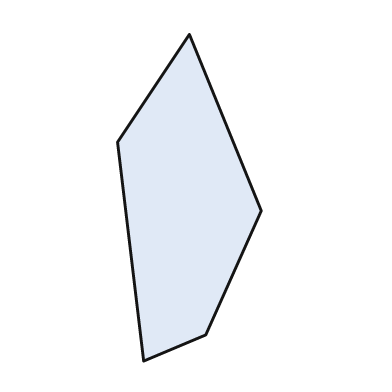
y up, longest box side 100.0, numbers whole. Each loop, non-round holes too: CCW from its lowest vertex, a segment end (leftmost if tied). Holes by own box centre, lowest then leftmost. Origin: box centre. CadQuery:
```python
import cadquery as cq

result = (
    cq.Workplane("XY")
    .moveTo(-14.0, -50.0)
    .lineTo(5.0, -42.0)
    .lineTo(22.0, -4.0)
    .lineTo(0.0, 50.0)
    .lineTo(-22.0, 17.0)
    .close()
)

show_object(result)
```